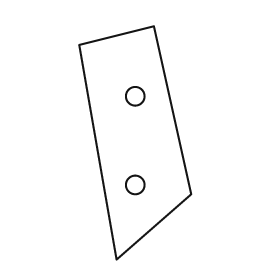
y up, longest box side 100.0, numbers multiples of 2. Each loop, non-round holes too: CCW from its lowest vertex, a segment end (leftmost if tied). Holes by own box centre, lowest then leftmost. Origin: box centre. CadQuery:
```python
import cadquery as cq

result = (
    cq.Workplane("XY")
    .moveTo(-8.0, -50.0)
    .lineTo(24.0, -22.0)
    .lineTo(8.0, 50.0)
    .lineTo(-24.0, 42.0)
    .close()
    .moveTo(0.0, -18.0)
    .circle(4.0)
    .moveTo(0.0, 20.0)
    .circle(4.0)
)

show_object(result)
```